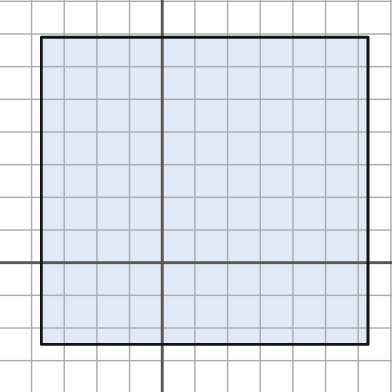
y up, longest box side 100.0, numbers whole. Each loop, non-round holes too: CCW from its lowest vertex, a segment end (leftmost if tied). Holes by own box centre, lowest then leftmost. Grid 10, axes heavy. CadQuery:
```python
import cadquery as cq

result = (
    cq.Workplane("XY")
    .moveTo(-37.0, -25.0)
    .lineTo(63.0, -25.0)
    .lineTo(63.0, 69.0)
    .lineTo(-37.0, 69.0)
    .close()
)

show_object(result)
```